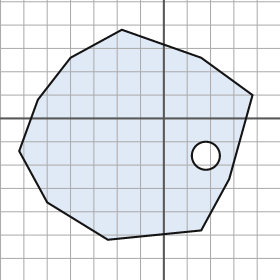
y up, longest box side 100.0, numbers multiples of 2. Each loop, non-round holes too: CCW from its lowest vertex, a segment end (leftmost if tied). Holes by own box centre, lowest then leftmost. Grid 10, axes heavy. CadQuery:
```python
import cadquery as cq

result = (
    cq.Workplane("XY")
    .moveTo(-24.0, -52.0)
    .lineTo(16.0, -48.0)
    .lineTo(28.0, -26.0)
    .lineTo(38.0, 10.0)
    .lineTo(16.0, 26.0)
    .lineTo(-18.0, 38.0)
    .lineTo(-40.0, 26.0)
    .lineTo(-54.0, 8.0)
    .lineTo(-62.0, -14.0)
    .lineTo(-50.0, -36.0)
    .close()
    .moveTo(18.0, -16.0)
    .circle(6.0)
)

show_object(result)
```